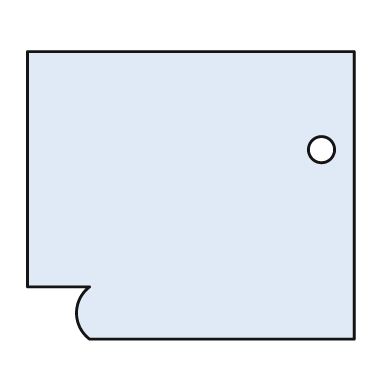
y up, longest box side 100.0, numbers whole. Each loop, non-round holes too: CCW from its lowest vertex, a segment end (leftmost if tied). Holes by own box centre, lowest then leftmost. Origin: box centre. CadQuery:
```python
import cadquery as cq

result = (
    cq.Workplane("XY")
    .moveTo(-31.0, -44.0)
    .lineTo(50.0, -44.0)
    .lineTo(50.0, 44.0)
    .lineTo(-50.0, 44.0)
    .lineTo(-50.0, -28.0)
    .lineTo(-31.0, -28.0)
    .threePointArc((-35.0, -36.0), (-31.0, -44.0))
    .close()
    .moveTo(40.0, 14.0)
    .circle(4.0)
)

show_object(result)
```